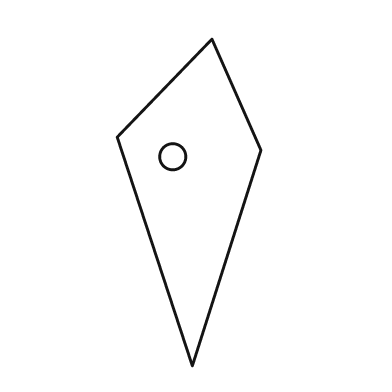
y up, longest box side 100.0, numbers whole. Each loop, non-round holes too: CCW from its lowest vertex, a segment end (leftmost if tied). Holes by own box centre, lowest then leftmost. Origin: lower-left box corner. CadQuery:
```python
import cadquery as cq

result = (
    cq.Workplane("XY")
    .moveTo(23.0, 0.0)
    .lineTo(44.0, 66.0)
    .lineTo(29.0, 100.0)
    .lineTo(0.0, 70.0)
    .close()
    .moveTo(17.0, 64.0)
    .circle(4.0)
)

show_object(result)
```